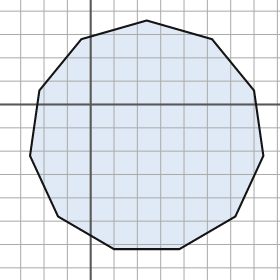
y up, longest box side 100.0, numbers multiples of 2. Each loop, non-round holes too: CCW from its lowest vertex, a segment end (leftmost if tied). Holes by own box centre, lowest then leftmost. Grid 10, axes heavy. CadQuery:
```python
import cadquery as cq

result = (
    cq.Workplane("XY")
    .moveTo(10.0, -62.0)
    .lineTo(38.0, -62.0)
    .lineTo(62.0, -48.0)
    .lineTo(74.0, -22.0)
    .lineTo(70.0, 6.0)
    .lineTo(52.0, 28.0)
    .lineTo(24.0, 36.0)
    .lineTo(-4.0, 28.0)
    .lineTo(-22.0, 6.0)
    .lineTo(-26.0, -22.0)
    .lineTo(-14.0, -48.0)
    .close()
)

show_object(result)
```